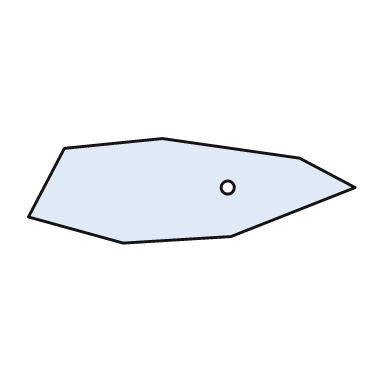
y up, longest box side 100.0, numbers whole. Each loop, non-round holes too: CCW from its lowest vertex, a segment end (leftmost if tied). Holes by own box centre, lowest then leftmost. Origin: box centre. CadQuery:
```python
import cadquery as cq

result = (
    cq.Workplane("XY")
    .moveTo(-21.0, -16.0)
    .lineTo(12.0, -14.0)
    .lineTo(50.0, 1.0)
    .lineTo(33.0, 10.0)
    .lineTo(-9.0, 16.0)
    .lineTo(-39.0, 13.0)
    .lineTo(-50.0, -8.0)
    .close()
    .moveTo(11.0, 1.0)
    .circle(2.0)
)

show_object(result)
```